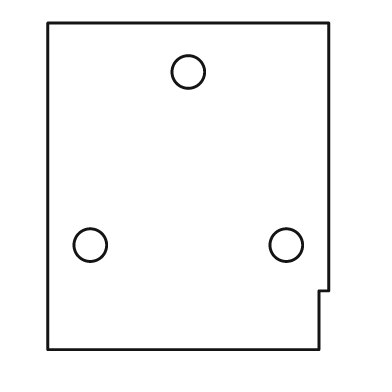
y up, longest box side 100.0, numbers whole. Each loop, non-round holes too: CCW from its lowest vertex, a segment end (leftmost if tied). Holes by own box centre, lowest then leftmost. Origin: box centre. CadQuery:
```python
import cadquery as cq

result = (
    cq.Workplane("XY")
    .moveTo(-43.0, -50.0)
    .lineTo(40.0, -50.0)
    .lineTo(40.0, -32.0)
    .lineTo(43.0, -32.0)
    .lineTo(43.0, 50.0)
    .lineTo(-43.0, 50.0)
    .close()
    .moveTo(-30.0, -18.0)
    .circle(5.0)
    .moveTo(30.0, -18.0)
    .circle(5.0)
    .moveTo(0.0, 35.0)
    .circle(5.0)
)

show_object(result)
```